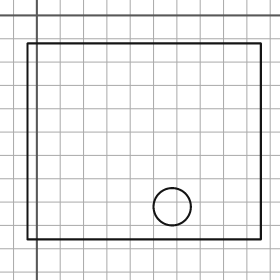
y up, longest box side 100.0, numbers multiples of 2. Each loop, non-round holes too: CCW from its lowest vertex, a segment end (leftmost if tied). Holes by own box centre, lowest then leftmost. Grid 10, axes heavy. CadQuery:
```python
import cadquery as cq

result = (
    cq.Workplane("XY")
    .moveTo(-4.0, -96.0)
    .lineTo(96.0, -96.0)
    .lineTo(96.0, -12.0)
    .lineTo(-4.0, -12.0)
    .close()
    .moveTo(58.0, -82.0)
    .circle(8.0)
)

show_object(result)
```